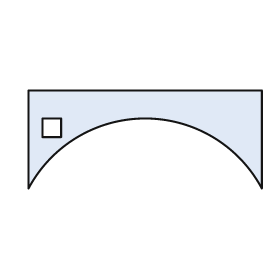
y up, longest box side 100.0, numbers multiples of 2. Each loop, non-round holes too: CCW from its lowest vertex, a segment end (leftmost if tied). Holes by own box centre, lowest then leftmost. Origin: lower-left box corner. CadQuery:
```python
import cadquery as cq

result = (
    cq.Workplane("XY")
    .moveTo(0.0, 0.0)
    .threePointArc((50.0, 30.0), (100.0, 0.0))
    .lineTo(100.0, 42.0)
    .lineTo(0.0, 42.0)
    .close()
    .moveTo(6.0, 22.0)
    .lineTo(14.0, 22.0)
    .lineTo(14.0, 30.0)
    .lineTo(6.0, 30.0)
    .close()
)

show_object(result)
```